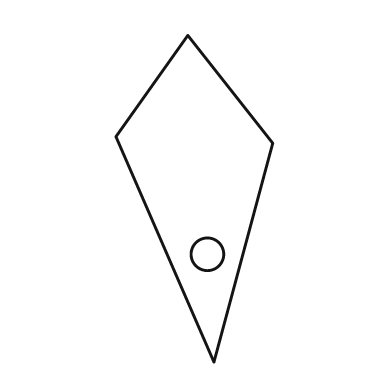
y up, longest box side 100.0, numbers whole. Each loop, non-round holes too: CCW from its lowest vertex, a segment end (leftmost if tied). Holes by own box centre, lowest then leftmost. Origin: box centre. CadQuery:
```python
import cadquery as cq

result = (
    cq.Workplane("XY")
    .moveTo(6.0, -50.0)
    .lineTo(24.0, 17.0)
    .lineTo(-2.0, 50.0)
    .lineTo(-24.0, 19.0)
    .close()
    .moveTo(4.0, -17.0)
    .circle(5.0)
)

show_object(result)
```